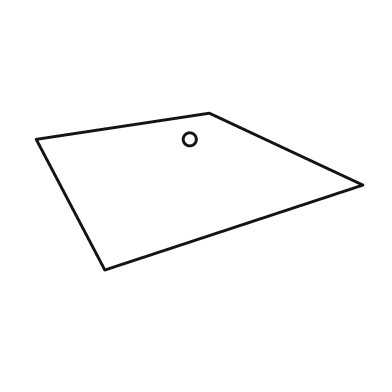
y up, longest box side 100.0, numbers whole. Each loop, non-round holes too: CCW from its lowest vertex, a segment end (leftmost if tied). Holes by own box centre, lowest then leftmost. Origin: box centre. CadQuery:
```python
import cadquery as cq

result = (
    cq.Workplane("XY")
    .moveTo(-29.0, -24.0)
    .lineTo(50.0, 2.0)
    .lineTo(3.0, 24.0)
    .lineTo(-50.0, 16.0)
    .close()
    .moveTo(-3.0, 16.0)
    .circle(2.0)
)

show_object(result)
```